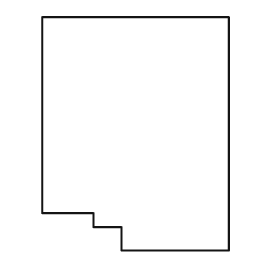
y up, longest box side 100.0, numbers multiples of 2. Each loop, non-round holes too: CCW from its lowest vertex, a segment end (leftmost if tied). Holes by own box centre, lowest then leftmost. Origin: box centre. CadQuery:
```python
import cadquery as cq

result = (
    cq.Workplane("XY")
    .moveTo(-6.0, -50.0)
    .lineTo(40.0, -50.0)
    .lineTo(40.0, 50.0)
    .lineTo(-40.0, 50.0)
    .lineTo(-40.0, -34.0)
    .lineTo(-18.0, -34.0)
    .lineTo(-18.0, -40.0)
    .lineTo(-6.0, -40.0)
    .close()
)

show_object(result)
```